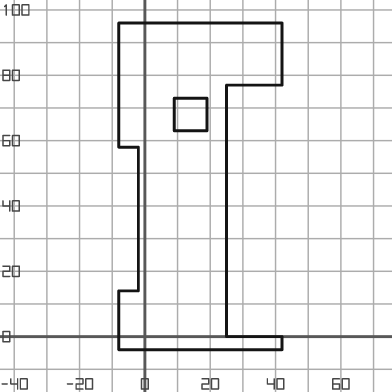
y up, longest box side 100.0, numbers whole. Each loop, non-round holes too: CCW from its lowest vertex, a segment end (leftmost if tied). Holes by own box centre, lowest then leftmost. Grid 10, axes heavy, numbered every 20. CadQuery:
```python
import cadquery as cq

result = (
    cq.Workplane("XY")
    .moveTo(-8.0, -4.0)
    .lineTo(42.0, -4.0)
    .lineTo(42.0, 0.0)
    .lineTo(25.0, 0.0)
    .lineTo(25.0, 77.0)
    .lineTo(42.0, 77.0)
    .lineTo(42.0, 96.0)
    .lineTo(-8.0, 96.0)
    .lineTo(-8.0, 58.0)
    .lineTo(-2.0, 58.0)
    .lineTo(-2.0, 14.0)
    .lineTo(-8.0, 14.0)
    .close()
    .moveTo(9.0, 63.0)
    .lineTo(19.0, 63.0)
    .lineTo(19.0, 73.0)
    .lineTo(9.0, 73.0)
    .close()
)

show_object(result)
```